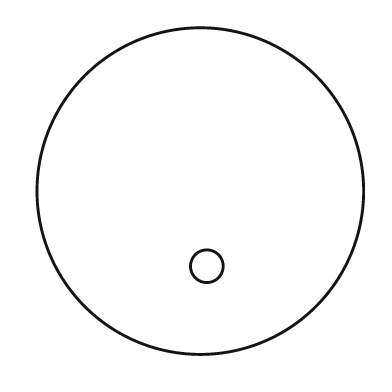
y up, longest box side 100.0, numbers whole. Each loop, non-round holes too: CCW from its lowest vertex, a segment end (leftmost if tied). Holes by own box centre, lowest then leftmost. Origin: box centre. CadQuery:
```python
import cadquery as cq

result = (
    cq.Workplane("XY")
    .moveTo(0.0, 0.0)
    .circle(50.0)
    .moveTo(2.0, -23.0)
    .circle(5.0)
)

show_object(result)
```